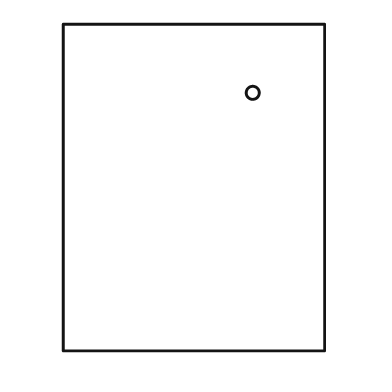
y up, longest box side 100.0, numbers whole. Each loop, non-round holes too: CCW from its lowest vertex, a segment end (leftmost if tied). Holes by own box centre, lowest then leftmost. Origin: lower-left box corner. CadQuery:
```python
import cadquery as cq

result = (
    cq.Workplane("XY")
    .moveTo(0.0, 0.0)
    .lineTo(80.0, 0.0)
    .lineTo(80.0, 100.0)
    .lineTo(0.0, 100.0)
    .close()
    .moveTo(58.0, 79.0)
    .circle(2.0)
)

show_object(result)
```